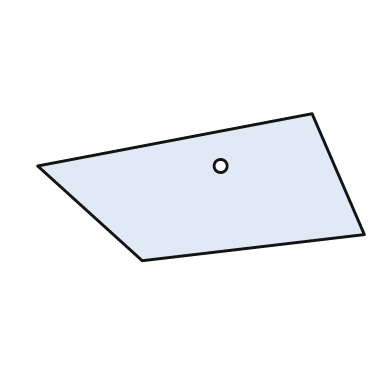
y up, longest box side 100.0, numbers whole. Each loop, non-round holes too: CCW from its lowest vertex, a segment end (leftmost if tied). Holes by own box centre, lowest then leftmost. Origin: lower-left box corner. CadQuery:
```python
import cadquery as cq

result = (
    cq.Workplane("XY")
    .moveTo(32.0, 0.0)
    .lineTo(100.0, 8.0)
    .lineTo(84.0, 45.0)
    .lineTo(0.0, 29.0)
    .close()
    .moveTo(56.0, 29.0)
    .circle(2.0)
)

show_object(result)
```